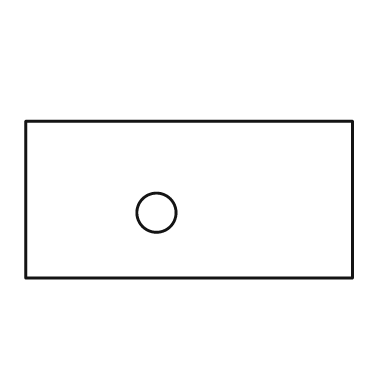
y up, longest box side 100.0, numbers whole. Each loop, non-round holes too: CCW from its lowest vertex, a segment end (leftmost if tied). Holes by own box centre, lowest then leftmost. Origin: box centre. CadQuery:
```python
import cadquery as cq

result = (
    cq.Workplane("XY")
    .moveTo(-50.0, -24.0)
    .lineTo(50.0, -24.0)
    .lineTo(50.0, 24.0)
    .lineTo(-50.0, 24.0)
    .close()
    .moveTo(-10.0, -4.0)
    .circle(6.0)
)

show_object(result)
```